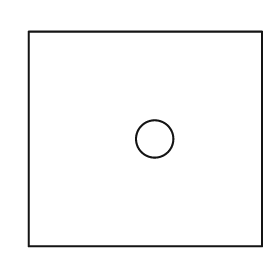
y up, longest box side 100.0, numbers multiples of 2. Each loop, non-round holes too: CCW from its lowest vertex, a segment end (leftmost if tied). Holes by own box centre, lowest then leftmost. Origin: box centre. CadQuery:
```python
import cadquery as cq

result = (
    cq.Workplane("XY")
    .moveTo(-50.0, -46.0)
    .lineTo(50.0, -46.0)
    .lineTo(50.0, 46.0)
    .lineTo(-50.0, 46.0)
    .close()
    .moveTo(4.0, 0.0)
    .circle(8.0)
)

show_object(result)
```